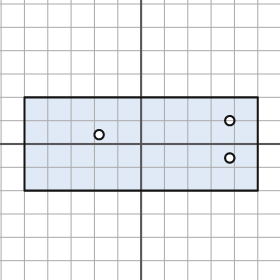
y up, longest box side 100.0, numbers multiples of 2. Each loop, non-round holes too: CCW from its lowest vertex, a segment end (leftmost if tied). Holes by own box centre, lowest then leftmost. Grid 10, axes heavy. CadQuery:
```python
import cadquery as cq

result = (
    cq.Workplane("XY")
    .moveTo(-50.0, -20.0)
    .lineTo(50.0, -20.0)
    .lineTo(50.0, 20.0)
    .lineTo(-50.0, 20.0)
    .close()
    .moveTo(38.0, -6.0)
    .circle(2.0)
    .moveTo(-18.0, 4.0)
    .circle(2.0)
    .moveTo(38.0, 10.0)
    .circle(2.0)
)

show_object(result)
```